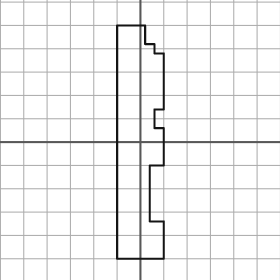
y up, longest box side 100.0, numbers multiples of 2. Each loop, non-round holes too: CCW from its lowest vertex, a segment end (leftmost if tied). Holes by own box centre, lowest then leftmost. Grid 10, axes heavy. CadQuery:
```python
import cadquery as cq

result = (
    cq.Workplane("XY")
    .moveTo(-10.0, -50.0)
    .lineTo(10.0, -50.0)
    .lineTo(10.0, -34.0)
    .lineTo(4.0, -34.0)
    .lineTo(4.0, -10.0)
    .lineTo(10.0, -10.0)
    .lineTo(10.0, 6.0)
    .lineTo(6.0, 6.0)
    .lineTo(6.0, 14.0)
    .lineTo(10.0, 14.0)
    .lineTo(10.0, 38.0)
    .lineTo(6.0, 38.0)
    .lineTo(6.0, 42.0)
    .lineTo(2.0, 42.0)
    .lineTo(2.0, 50.0)
    .lineTo(-10.0, 50.0)
    .close()
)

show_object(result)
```